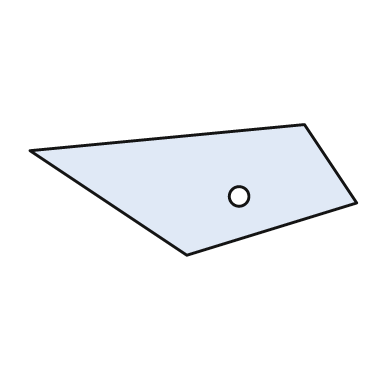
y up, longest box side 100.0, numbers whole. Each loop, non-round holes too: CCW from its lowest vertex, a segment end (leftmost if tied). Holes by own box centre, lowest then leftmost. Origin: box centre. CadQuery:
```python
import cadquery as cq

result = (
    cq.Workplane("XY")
    .moveTo(-2.0, -20.0)
    .lineTo(50.0, -4.0)
    .lineTo(34.0, 20.0)
    .lineTo(-50.0, 12.0)
    .close()
    .moveTo(14.0, -2.0)
    .circle(3.0)
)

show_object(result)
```